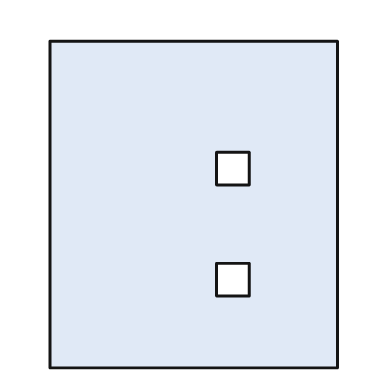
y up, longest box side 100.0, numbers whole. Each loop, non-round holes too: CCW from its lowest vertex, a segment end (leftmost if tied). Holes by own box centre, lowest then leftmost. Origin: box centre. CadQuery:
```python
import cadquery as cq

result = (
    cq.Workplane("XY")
    .moveTo(-44.0, -50.0)
    .lineTo(44.0, -50.0)
    .lineTo(44.0, 50.0)
    .lineTo(-44.0, 50.0)
    .close()
    .moveTo(7.0, -28.0)
    .lineTo(17.0, -28.0)
    .lineTo(17.0, -18.0)
    .lineTo(7.0, -18.0)
    .close()
    .moveTo(7.0, 6.0)
    .lineTo(17.0, 6.0)
    .lineTo(17.0, 16.0)
    .lineTo(7.0, 16.0)
    .close()
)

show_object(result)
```